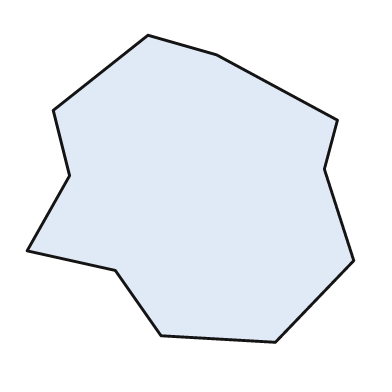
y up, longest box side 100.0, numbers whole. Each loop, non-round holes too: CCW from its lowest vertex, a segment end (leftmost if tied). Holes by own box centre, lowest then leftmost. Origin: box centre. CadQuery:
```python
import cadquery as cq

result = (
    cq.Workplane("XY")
    .moveTo(26.0, -47.0)
    .lineTo(50.0, -22.0)
    .lineTo(41.0, 6.0)
    .lineTo(45.0, 21.0)
    .lineTo(8.0, 41.0)
    .lineTo(-13.0, 47.0)
    .lineTo(-42.0, 24.0)
    .lineTo(-37.0, 4.0)
    .lineTo(-50.0, -19.0)
    .lineTo(-23.0, -25.0)
    .lineTo(-9.0, -45.0)
    .close()
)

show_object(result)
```